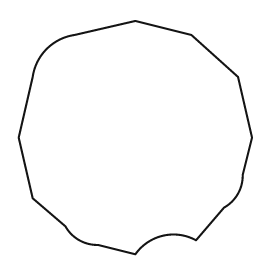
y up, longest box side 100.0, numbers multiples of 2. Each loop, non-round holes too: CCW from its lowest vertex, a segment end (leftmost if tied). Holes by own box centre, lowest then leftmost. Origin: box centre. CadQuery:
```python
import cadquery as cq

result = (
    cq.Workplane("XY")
    .moveTo(0.0, -50.0)
    .threePointArc((12.0, -42.0), (26.0, -44.0))
    .lineTo(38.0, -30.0)
    .threePointArc((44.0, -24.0), (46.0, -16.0))
    .lineTo(50.0, 0.0)
    .lineTo(44.0, 26.0)
    .lineTo(24.0, 44.0)
    .lineTo(0.0, 50.0)
    .lineTo(-26.0, 44.0)
    .threePointArc((-38.0, 38.0), (-44.0, 26.0))
    .lineTo(-50.0, 0.0)
    .lineTo(-44.0, -26.0)
    .lineTo(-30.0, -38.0)
    .threePointArc((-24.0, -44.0), (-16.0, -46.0))
    .close()
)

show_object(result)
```